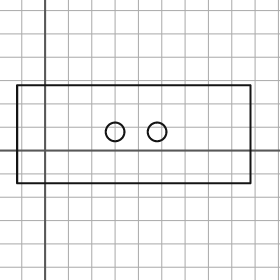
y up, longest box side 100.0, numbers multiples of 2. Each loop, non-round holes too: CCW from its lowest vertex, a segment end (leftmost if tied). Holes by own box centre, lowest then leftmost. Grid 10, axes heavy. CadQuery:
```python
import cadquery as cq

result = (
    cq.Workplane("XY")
    .moveTo(-12.0, -14.0)
    .lineTo(88.0, -14.0)
    .lineTo(88.0, 28.0)
    .lineTo(-12.0, 28.0)
    .close()
    .moveTo(30.0, 8.0)
    .circle(4.0)
    .moveTo(48.0, 8.0)
    .circle(4.0)
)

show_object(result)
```